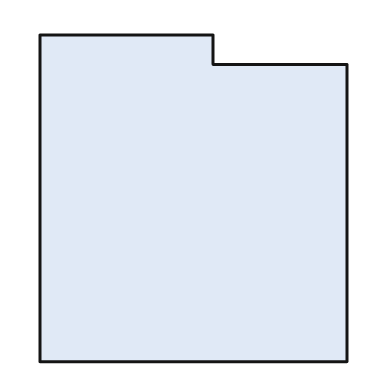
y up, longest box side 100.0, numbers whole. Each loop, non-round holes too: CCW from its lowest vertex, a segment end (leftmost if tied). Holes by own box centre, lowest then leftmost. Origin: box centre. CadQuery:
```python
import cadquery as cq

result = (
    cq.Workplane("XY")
    .moveTo(-47.0, -50.0)
    .lineTo(47.0, -50.0)
    .lineTo(47.0, 41.0)
    .lineTo(6.0, 41.0)
    .lineTo(6.0, 50.0)
    .lineTo(-47.0, 50.0)
    .close()
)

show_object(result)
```